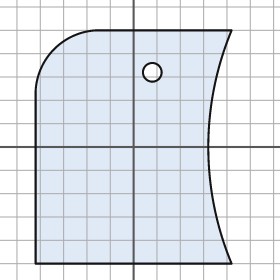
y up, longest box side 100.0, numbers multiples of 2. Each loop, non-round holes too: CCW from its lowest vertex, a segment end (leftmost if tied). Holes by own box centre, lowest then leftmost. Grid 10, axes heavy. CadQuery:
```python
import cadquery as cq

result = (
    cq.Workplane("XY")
    .moveTo(-42.0, -50.0)
    .lineTo(42.0, -50.0)
    .threePointArc((32.0, 0.0), (42.0, 50.0))
    .lineTo(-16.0, 50.0)
    .threePointArc((-34.0, 42.0), (-42.0, 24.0))
    .close()
    .moveTo(8.0, 32.0)
    .circle(4.0)
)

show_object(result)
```